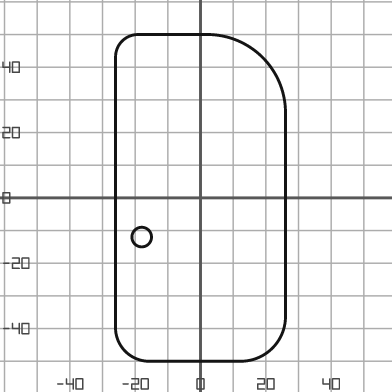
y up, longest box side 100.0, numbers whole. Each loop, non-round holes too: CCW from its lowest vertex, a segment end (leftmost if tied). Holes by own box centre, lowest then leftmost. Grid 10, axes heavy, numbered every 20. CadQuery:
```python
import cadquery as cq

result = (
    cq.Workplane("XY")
    .moveTo(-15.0, -50.0)
    .lineTo(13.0, -50.0)
    .threePointArc((22.0, -46.0), (26.0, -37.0))
    .lineTo(26.0, 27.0)
    .threePointArc((19.0, 43.0), (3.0, 50.0))
    .lineTo(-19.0, 50.0)
    .threePointArc((-24.0, 48.0), (-26.0, 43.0))
    .lineTo(-26.0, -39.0)
    .threePointArc((-23.0, -47.0), (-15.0, -50.0))
    .close()
    .moveTo(-18.0, -12.0)
    .circle(3.0)
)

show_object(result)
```